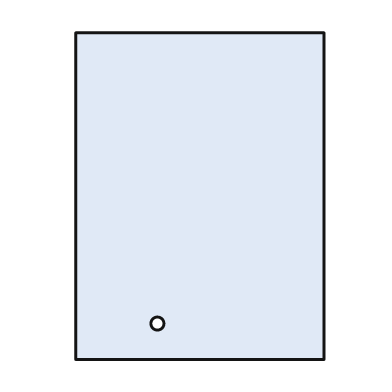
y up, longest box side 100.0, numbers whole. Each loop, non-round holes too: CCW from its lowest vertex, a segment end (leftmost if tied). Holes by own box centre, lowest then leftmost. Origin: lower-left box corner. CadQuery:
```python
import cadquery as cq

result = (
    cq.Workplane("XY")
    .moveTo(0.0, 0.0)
    .lineTo(76.0, 0.0)
    .lineTo(76.0, 100.0)
    .lineTo(0.0, 100.0)
    .close()
    .moveTo(25.0, 11.0)
    .circle(2.0)
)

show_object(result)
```